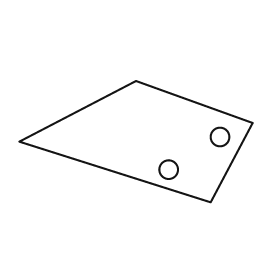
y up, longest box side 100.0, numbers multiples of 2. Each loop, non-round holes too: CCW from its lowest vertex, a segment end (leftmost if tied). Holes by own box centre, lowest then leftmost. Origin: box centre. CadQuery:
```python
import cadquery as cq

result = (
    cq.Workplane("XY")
    .moveTo(32.0, -26.0)
    .lineTo(50.0, 8.0)
    .lineTo(0.0, 26.0)
    .lineTo(-50.0, 0.0)
    .close()
    .moveTo(14.0, -12.0)
    .circle(4.0)
    .moveTo(36.0, 2.0)
    .circle(4.0)
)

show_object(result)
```